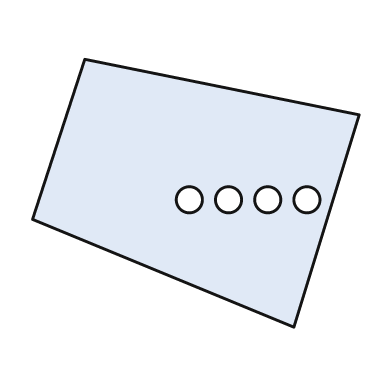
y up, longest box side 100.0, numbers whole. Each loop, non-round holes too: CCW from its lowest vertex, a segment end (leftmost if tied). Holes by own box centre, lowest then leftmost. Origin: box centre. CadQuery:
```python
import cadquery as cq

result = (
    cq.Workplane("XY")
    .moveTo(30.0, -41.0)
    .lineTo(50.0, 24.0)
    .lineTo(-34.0, 41.0)
    .lineTo(-50.0, -8.0)
    .close()
    .moveTo(-2.0, -2.0)
    .circle(4.0)
    .moveTo(10.0, -2.0)
    .circle(4.0)
    .moveTo(22.0, -2.0)
    .circle(4.0)
    .moveTo(34.0, -2.0)
    .circle(4.0)
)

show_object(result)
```